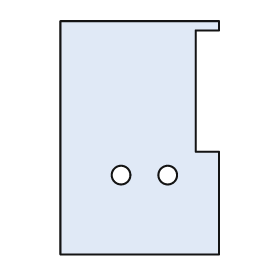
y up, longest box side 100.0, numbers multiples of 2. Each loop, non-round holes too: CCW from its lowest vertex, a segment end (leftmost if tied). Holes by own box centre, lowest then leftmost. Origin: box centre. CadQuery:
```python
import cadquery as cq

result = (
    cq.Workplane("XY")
    .moveTo(-34.0, -50.0)
    .lineTo(34.0, -50.0)
    .lineTo(34.0, -6.0)
    .lineTo(24.0, -6.0)
    .lineTo(24.0, 46.0)
    .lineTo(34.0, 46.0)
    .lineTo(34.0, 50.0)
    .lineTo(-34.0, 50.0)
    .close()
    .moveTo(-8.0, -16.0)
    .circle(4.0)
    .moveTo(12.0, -16.0)
    .circle(4.0)
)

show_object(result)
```